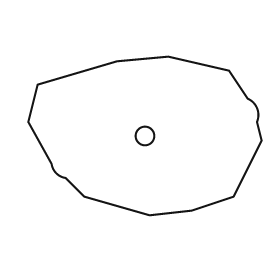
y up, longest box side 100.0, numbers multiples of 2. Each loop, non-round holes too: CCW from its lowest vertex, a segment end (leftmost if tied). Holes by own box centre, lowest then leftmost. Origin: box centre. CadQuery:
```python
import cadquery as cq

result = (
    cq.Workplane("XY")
    .moveTo(2.0, -34.0)
    .lineTo(20.0, -32.0)
    .lineTo(38.0, -26.0)
    .lineTo(50.0, -2.0)
    .lineTo(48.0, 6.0)
    .threePointArc((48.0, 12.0), (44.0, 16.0))
    .lineTo(36.0, 28.0)
    .lineTo(10.0, 34.0)
    .lineTo(-12.0, 32.0)
    .lineTo(-46.0, 22.0)
    .lineTo(-50.0, 6.0)
    .lineTo(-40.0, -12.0)
    .threePointArc((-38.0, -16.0), (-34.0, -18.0))
    .lineTo(-26.0, -26.0)
    .close()
    .moveTo(0.0, 0.0)
    .circle(4.0)
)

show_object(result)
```